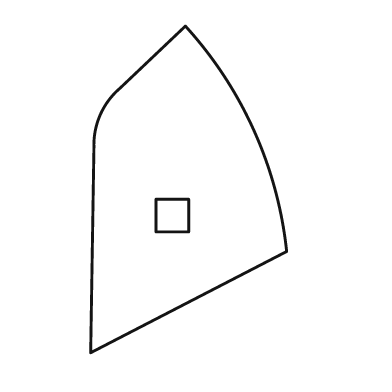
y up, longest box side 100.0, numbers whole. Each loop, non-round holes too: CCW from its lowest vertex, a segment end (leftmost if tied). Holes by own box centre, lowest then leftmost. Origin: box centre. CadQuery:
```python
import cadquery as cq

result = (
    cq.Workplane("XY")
    .moveTo(-30.0, -50.0)
    .lineTo(30.0, -19.0)
    .threePointArc((20.0, 18.0), (-1.0, 50.0))
    .lineTo(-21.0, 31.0)
    .threePointArc((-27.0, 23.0), (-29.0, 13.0))
    .close()
    .moveTo(-10.0, -13.0)
    .lineTo(0.0, -13.0)
    .lineTo(0.0, -3.0)
    .lineTo(-10.0, -3.0)
    .close()
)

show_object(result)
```